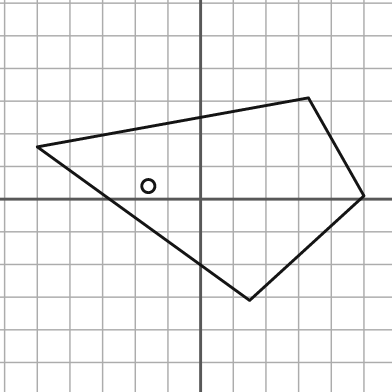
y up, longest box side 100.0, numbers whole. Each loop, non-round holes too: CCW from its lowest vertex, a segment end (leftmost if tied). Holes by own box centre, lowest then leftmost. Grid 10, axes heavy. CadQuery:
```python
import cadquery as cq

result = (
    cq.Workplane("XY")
    .moveTo(15.0, -31.0)
    .lineTo(50.0, 1.0)
    .lineTo(33.0, 31.0)
    .lineTo(-50.0, 16.0)
    .close()
    .moveTo(-16.0, 4.0)
    .circle(2.0)
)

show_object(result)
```